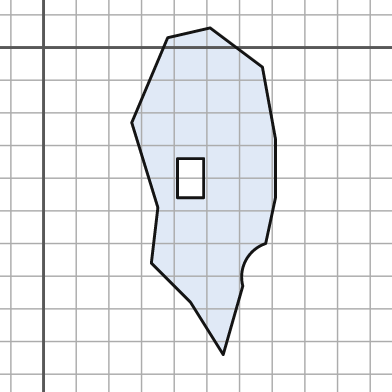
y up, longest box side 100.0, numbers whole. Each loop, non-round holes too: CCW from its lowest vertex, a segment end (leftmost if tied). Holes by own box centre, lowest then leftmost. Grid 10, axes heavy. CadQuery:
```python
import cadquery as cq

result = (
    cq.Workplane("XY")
    .moveTo(55.0, -94.0)
    .lineTo(61.0, -73.0)
    .threePointArc((62.0, -65.0), (68.0, -60.0))
    .lineTo(71.0, -46.0)
    .lineTo(71.0, -28.0)
    .lineTo(67.0, -6.0)
    .lineTo(51.0, 6.0)
    .lineTo(38.0, 3.0)
    .lineTo(27.0, -23.0)
    .lineTo(35.0, -49.0)
    .lineTo(33.0, -66.0)
    .lineTo(45.0, -78.0)
    .close()
    .moveTo(41.0, -46.0)
    .lineTo(49.0, -46.0)
    .lineTo(49.0, -34.0)
    .lineTo(41.0, -34.0)
    .close()
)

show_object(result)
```